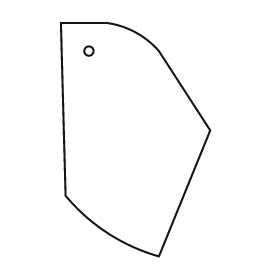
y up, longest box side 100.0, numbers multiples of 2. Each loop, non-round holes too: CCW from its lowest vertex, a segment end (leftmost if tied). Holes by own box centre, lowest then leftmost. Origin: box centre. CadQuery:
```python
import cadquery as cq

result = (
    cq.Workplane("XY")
    .moveTo(10.0, -50.0)
    .lineTo(32.0, 4.0)
    .lineTo(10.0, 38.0)
    .threePointArc((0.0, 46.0), (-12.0, 50.0))
    .lineTo(-32.0, 50.0)
    .lineTo(-30.0, -24.0)
    .threePointArc((-12.0, -40.0), (10.0, -50.0))
    .close()
    .moveTo(-20.0, 38.0)
    .circle(2.0)
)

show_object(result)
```